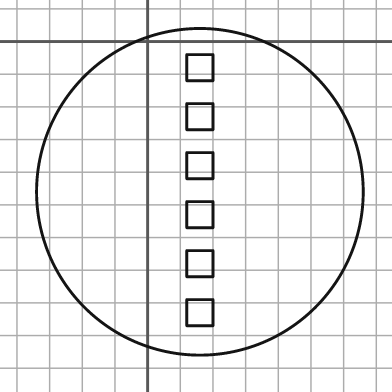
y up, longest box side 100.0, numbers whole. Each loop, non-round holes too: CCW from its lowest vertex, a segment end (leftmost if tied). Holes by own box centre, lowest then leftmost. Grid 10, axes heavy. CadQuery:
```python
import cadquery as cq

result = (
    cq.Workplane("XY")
    .moveTo(16.0, -46.0)
    .circle(50.0)
    .moveTo(12.0, -87.0)
    .lineTo(20.0, -87.0)
    .lineTo(20.0, -79.0)
    .lineTo(12.0, -79.0)
    .close()
    .moveTo(12.0, -72.0)
    .lineTo(20.0, -72.0)
    .lineTo(20.0, -64.0)
    .lineTo(12.0, -64.0)
    .close()
    .moveTo(12.0, -57.0)
    .lineTo(20.0, -57.0)
    .lineTo(20.0, -49.0)
    .lineTo(12.0, -49.0)
    .close()
    .moveTo(12.0, -42.0)
    .lineTo(20.0, -42.0)
    .lineTo(20.0, -34.0)
    .lineTo(12.0, -34.0)
    .close()
    .moveTo(12.0, -27.0)
    .lineTo(20.0, -27.0)
    .lineTo(20.0, -19.0)
    .lineTo(12.0, -19.0)
    .close()
    .moveTo(12.0, -12.0)
    .lineTo(20.0, -12.0)
    .lineTo(20.0, -4.0)
    .lineTo(12.0, -4.0)
    .close()
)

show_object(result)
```